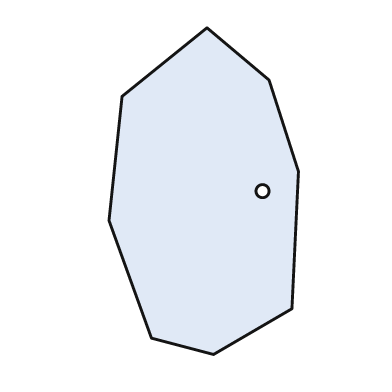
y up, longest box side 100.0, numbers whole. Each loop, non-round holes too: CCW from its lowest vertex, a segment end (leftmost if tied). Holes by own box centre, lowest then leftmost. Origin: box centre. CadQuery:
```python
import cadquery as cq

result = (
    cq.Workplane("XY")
    .moveTo(3.0, -50.0)
    .lineTo(27.0, -36.0)
    .lineTo(29.0, 6.0)
    .lineTo(20.0, 34.0)
    .lineTo(1.0, 50.0)
    .lineTo(-25.0, 29.0)
    .lineTo(-29.0, -9.0)
    .lineTo(-16.0, -45.0)
    .close()
    .moveTo(18.0, 0.0)
    .circle(2.0)
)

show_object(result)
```